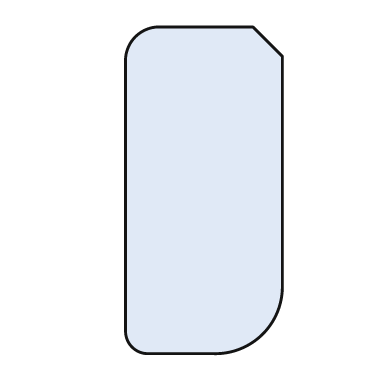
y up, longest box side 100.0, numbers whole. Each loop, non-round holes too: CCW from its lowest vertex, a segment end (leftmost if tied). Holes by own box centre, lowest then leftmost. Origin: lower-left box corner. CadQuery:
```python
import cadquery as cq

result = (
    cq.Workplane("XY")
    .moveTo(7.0, 0.0)
    .lineTo(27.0, 0.0)
    .threePointArc((42.0, 6.0), (48.0, 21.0))
    .lineTo(48.0, 91.0)
    .lineTo(39.0, 100.0)
    .lineTo(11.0, 100.0)
    .threePointArc((3.0, 97.0), (0.0, 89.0))
    .lineTo(0.0, 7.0)
    .threePointArc((2.0, 2.0), (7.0, 0.0))
    .close()
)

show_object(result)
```